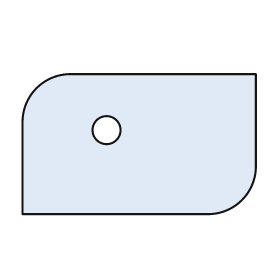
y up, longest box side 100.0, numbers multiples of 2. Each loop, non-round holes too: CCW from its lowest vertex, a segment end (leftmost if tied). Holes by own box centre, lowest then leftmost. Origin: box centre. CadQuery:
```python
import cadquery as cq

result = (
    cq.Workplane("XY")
    .moveTo(-50.0, -30.0)
    .lineTo(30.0, -30.0)
    .threePointArc((44.0, -24.0), (50.0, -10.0))
    .lineTo(50.0, 30.0)
    .lineTo(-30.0, 30.0)
    .threePointArc((-44.0, 24.0), (-50.0, 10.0))
    .close()
    .moveTo(-14.0, 6.0)
    .circle(6.0)
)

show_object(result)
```